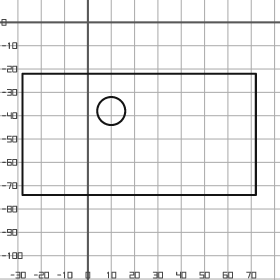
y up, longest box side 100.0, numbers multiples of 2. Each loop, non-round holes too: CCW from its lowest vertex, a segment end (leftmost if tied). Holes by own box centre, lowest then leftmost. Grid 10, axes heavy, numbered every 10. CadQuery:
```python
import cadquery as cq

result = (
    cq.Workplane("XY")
    .moveTo(-28.0, -74.0)
    .lineTo(72.0, -74.0)
    .lineTo(72.0, -22.0)
    .lineTo(-28.0, -22.0)
    .close()
    .moveTo(10.0, -38.0)
    .circle(6.0)
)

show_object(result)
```